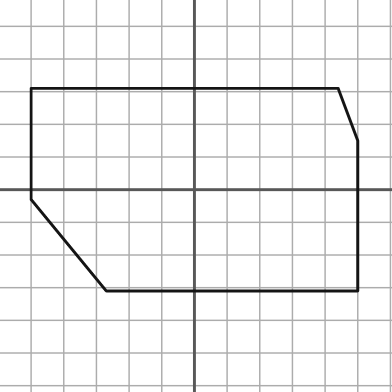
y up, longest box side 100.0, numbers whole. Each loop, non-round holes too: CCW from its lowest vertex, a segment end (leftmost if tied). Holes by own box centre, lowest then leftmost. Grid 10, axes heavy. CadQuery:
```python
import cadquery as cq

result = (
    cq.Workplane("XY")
    .moveTo(-27.0, -31.0)
    .lineTo(50.0, -31.0)
    .lineTo(50.0, 15.0)
    .lineTo(44.0, 31.0)
    .lineTo(-50.0, 31.0)
    .lineTo(-50.0, -3.0)
    .close()
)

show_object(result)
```